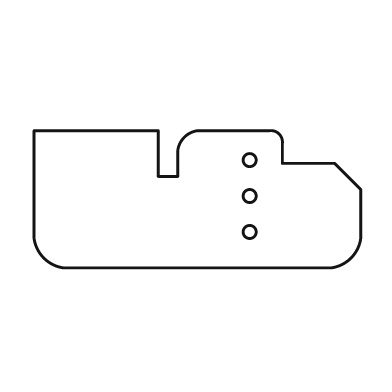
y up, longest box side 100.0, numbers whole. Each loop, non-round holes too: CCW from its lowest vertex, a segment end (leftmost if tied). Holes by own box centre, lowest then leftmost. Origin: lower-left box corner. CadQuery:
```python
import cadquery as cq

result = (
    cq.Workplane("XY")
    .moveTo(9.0, 0.0)
    .lineTo(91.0, 0.0)
    .threePointArc((97.0, 3.0), (100.0, 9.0))
    .lineTo(100.0, 24.0)
    .lineTo(92.0, 32.0)
    .lineTo(76.0, 32.0)
    .lineTo(76.0, 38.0)
    .threePointArc((75.0, 41.0), (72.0, 42.0))
    .lineTo(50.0, 42.0)
    .threePointArc((46.0, 40.0), (44.0, 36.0))
    .lineTo(44.0, 28.0)
    .lineTo(38.0, 28.0)
    .lineTo(38.0, 42.0)
    .lineTo(0.0, 42.0)
    .lineTo(0.0, 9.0)
    .threePointArc((3.0, 3.0), (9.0, 0.0))
    .close()
    .moveTo(66.0, 11.0)
    .circle(2.0)
    .moveTo(66.0, 22.0)
    .circle(2.0)
    .moveTo(66.0, 33.0)
    .circle(2.0)
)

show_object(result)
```